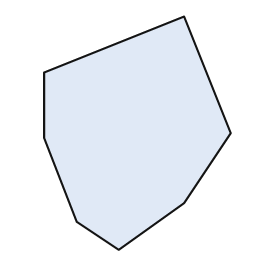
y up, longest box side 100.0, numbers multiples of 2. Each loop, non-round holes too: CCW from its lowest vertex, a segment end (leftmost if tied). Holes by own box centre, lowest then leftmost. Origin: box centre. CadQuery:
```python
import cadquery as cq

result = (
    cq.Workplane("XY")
    .moveTo(-8.0, -50.0)
    .lineTo(20.0, -30.0)
    .lineTo(40.0, 0.0)
    .lineTo(20.0, 50.0)
    .lineTo(-40.0, 26.0)
    .lineTo(-40.0, -2.0)
    .lineTo(-26.0, -38.0)
    .close()
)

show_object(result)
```